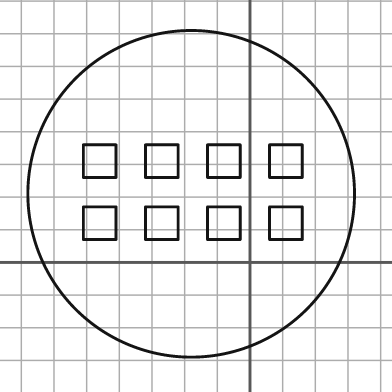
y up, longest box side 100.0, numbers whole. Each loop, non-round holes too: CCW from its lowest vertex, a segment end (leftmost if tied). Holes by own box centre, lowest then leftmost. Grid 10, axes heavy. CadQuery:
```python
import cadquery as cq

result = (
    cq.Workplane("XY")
    .moveTo(-18.0, 21.0)
    .circle(50.0)
    .moveTo(-51.0, 7.0)
    .lineTo(-41.0, 7.0)
    .lineTo(-41.0, 17.0)
    .lineTo(-51.0, 17.0)
    .close()
    .moveTo(-32.0, 7.0)
    .lineTo(-22.0, 7.0)
    .lineTo(-22.0, 17.0)
    .lineTo(-32.0, 17.0)
    .close()
    .moveTo(-13.0, 7.0)
    .lineTo(-3.0, 7.0)
    .lineTo(-3.0, 17.0)
    .lineTo(-13.0, 17.0)
    .close()
    .moveTo(6.0, 7.0)
    .lineTo(16.0, 7.0)
    .lineTo(16.0, 17.0)
    .lineTo(6.0, 17.0)
    .close()
    .moveTo(-51.0, 26.0)
    .lineTo(-41.0, 26.0)
    .lineTo(-41.0, 36.0)
    .lineTo(-51.0, 36.0)
    .close()
    .moveTo(-32.0, 26.0)
    .lineTo(-22.0, 26.0)
    .lineTo(-22.0, 36.0)
    .lineTo(-32.0, 36.0)
    .close()
    .moveTo(-13.0, 26.0)
    .lineTo(-3.0, 26.0)
    .lineTo(-3.0, 36.0)
    .lineTo(-13.0, 36.0)
    .close()
    .moveTo(6.0, 26.0)
    .lineTo(16.0, 26.0)
    .lineTo(16.0, 36.0)
    .lineTo(6.0, 36.0)
    .close()
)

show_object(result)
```